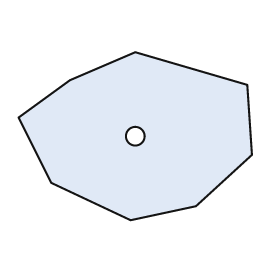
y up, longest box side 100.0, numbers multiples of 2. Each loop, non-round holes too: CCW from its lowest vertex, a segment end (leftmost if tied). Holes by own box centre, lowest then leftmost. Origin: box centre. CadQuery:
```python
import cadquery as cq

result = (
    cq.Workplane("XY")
    .moveTo(-2.0, -36.0)
    .lineTo(26.0, -30.0)
    .lineTo(50.0, -8.0)
    .lineTo(48.0, 22.0)
    .lineTo(0.0, 36.0)
    .lineTo(-28.0, 24.0)
    .lineTo(-50.0, 8.0)
    .lineTo(-36.0, -20.0)
    .close()
    .moveTo(0.0, 0.0)
    .circle(4.0)
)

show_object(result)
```